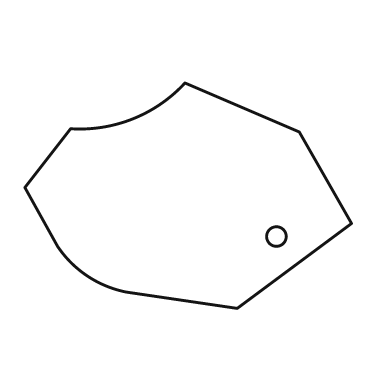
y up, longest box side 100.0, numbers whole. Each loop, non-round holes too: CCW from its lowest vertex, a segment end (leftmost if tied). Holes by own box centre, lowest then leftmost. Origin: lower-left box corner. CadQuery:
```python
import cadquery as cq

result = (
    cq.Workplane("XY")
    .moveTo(65.0, 0.0)
    .lineTo(100.0, 26.0)
    .lineTo(84.0, 54.0)
    .lineTo(49.0, 69.0)
    .threePointArc((33.0, 58.0), (14.0, 55.0))
    .lineTo(0.0, 37.0)
    .lineTo(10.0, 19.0)
    .threePointArc((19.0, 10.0), (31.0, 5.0))
    .close()
    .moveTo(77.0, 22.0)
    .circle(3.0)
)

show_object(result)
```